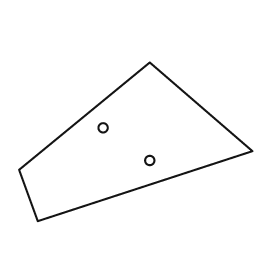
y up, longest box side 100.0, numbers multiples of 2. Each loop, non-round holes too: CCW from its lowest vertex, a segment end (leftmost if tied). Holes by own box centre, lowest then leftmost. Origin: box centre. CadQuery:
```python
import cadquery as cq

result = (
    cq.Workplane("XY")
    .moveTo(-42.0, -34.0)
    .lineTo(50.0, -4.0)
    .lineTo(6.0, 34.0)
    .lineTo(-50.0, -12.0)
    .close()
    .moveTo(6.0, -8.0)
    .circle(2.0)
    .moveTo(-14.0, 6.0)
    .circle(2.0)
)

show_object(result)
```